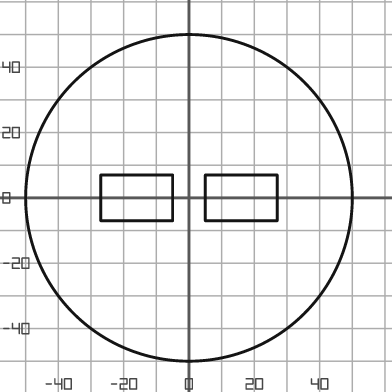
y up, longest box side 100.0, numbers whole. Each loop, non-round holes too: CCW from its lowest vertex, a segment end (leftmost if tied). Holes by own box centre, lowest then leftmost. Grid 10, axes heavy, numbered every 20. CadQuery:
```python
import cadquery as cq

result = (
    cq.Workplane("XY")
    .moveTo(0.0, 0.0)
    .circle(50.0)
    .moveTo(-27.0, -7.0)
    .lineTo(-5.0, -7.0)
    .lineTo(-5.0, 7.0)
    .lineTo(-27.0, 7.0)
    .close()
    .moveTo(5.0, -7.0)
    .lineTo(27.0, -7.0)
    .lineTo(27.0, 7.0)
    .lineTo(5.0, 7.0)
    .close()
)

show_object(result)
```